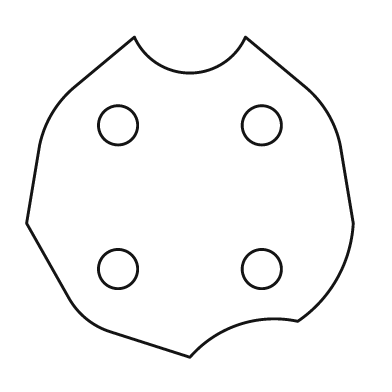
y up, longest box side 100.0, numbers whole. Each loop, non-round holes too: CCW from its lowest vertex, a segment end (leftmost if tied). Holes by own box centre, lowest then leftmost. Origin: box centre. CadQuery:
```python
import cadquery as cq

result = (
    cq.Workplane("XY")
    .moveTo(0.0, -49.0)
    .threePointArc((15.0, -39.0), (33.0, -38.0))
    .threePointArc((45.0, -25.0), (50.0, -8.0))
    .lineTo(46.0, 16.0)
    .threePointArc((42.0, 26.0), (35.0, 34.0))
    .lineTo(17.0, 49.0)
    .threePointArc((0.0, 38.0), (-17.0, 49.0))
    .lineTo(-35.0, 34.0)
    .threePointArc((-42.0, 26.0), (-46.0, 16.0))
    .lineTo(-50.0, -8.0)
    .lineTo(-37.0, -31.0)
    .threePointArc((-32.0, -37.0), (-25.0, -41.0))
    .close()
    .moveTo(-22.0, -22.0)
    .circle(6.0)
    .moveTo(22.0, -22.0)
    .circle(6.0)
    .moveTo(-22.0, 22.0)
    .circle(6.0)
    .moveTo(22.0, 22.0)
    .circle(6.0)
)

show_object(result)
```